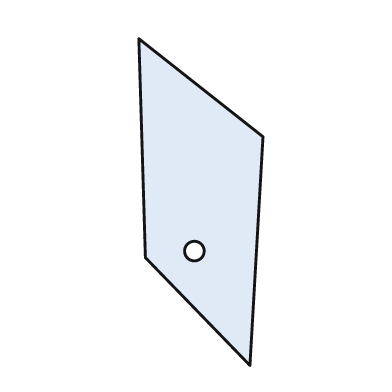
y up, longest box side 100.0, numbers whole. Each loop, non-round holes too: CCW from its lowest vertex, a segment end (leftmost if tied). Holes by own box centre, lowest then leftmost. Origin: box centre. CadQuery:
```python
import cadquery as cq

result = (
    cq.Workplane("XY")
    .moveTo(15.0, -50.0)
    .lineTo(19.0, 20.0)
    .lineTo(-19.0, 50.0)
    .lineTo(-17.0, -17.0)
    .close()
    .moveTo(-2.0, -15.0)
    .circle(3.0)
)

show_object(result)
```